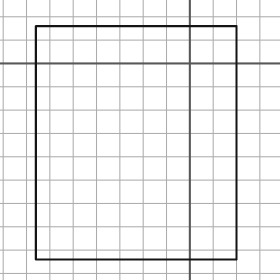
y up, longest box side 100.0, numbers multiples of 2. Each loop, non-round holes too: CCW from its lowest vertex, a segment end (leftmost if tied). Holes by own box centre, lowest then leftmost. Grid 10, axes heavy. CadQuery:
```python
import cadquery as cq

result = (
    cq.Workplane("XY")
    .moveTo(-66.0, -84.0)
    .lineTo(20.0, -84.0)
    .lineTo(20.0, 16.0)
    .lineTo(-66.0, 16.0)
    .close()
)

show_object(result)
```